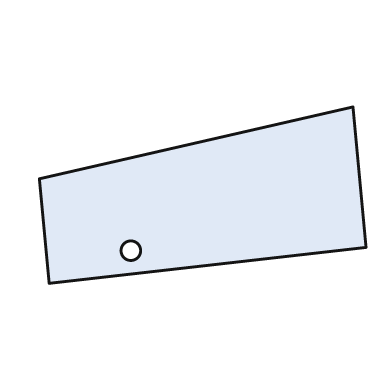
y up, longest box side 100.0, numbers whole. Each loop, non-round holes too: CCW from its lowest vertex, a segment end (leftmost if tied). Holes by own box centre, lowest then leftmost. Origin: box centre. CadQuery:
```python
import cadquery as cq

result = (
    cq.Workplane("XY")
    .moveTo(-47.0, -27.0)
    .lineTo(50.0, -16.0)
    .lineTo(46.0, 27.0)
    .lineTo(-50.0, 5.0)
    .close()
    .moveTo(-22.0, -17.0)
    .circle(3.0)
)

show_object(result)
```